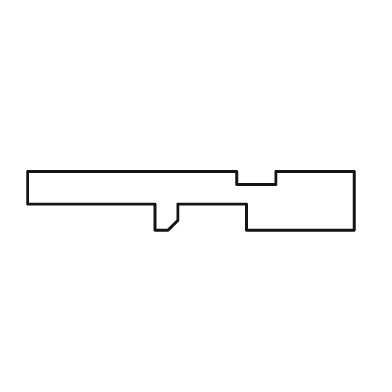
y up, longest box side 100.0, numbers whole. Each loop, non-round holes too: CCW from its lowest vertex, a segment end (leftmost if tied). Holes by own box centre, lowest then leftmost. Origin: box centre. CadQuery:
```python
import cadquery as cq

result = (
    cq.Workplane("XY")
    .moveTo(-11.0, -9.0)
    .lineTo(-7.0, -9.0)
    .lineTo(-4.0, -6.0)
    .lineTo(-4.0, -1.0)
    .lineTo(17.0, -1.0)
    .lineTo(17.0, -9.0)
    .lineTo(50.0, -9.0)
    .lineTo(50.0, 9.0)
    .lineTo(26.0, 9.0)
    .lineTo(26.0, 5.0)
    .lineTo(14.0, 5.0)
    .lineTo(14.0, 9.0)
    .lineTo(-50.0, 9.0)
    .lineTo(-50.0, -1.0)
    .lineTo(-11.0, -1.0)
    .close()
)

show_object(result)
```